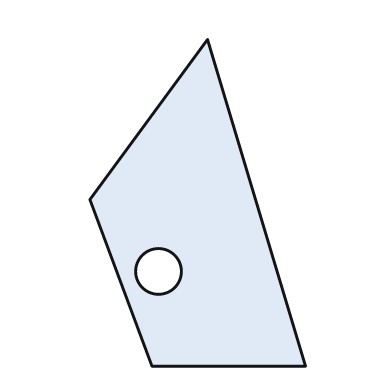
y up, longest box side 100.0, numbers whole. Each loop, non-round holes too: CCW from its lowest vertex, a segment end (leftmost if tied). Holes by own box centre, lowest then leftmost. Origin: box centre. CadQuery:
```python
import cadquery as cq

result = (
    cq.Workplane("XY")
    .moveTo(-14.0, -50.0)
    .lineTo(33.0, -50.0)
    .lineTo(3.0, 50.0)
    .lineTo(-33.0, 1.0)
    .close()
    .moveTo(-12.0, -21.0)
    .circle(7.0)
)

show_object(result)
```